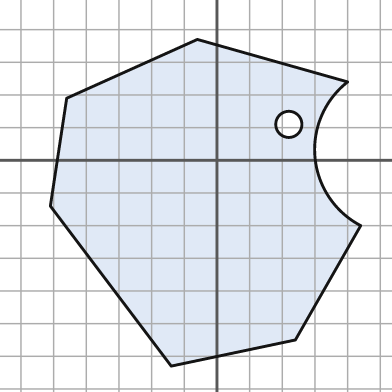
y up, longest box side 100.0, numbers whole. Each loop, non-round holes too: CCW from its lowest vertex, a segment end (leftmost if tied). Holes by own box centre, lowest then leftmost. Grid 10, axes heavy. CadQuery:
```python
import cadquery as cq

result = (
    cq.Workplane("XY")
    .moveTo(-14.0, -63.0)
    .lineTo(24.0, -55.0)
    .lineTo(44.0, -20.0)
    .threePointArc((30.0, 1.0), (40.0, 24.0))
    .lineTo(-6.0, 37.0)
    .lineTo(-46.0, 19.0)
    .lineTo(-51.0, -14.0)
    .close()
    .moveTo(22.0, 11.0)
    .circle(4.0)
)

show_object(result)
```